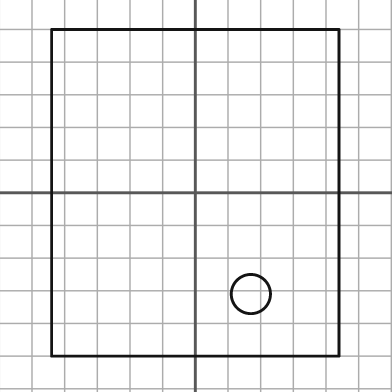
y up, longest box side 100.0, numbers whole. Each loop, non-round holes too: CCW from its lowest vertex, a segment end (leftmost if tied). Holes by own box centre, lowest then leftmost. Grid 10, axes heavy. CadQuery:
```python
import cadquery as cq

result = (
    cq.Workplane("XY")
    .moveTo(-44.0, -50.0)
    .lineTo(44.0, -50.0)
    .lineTo(44.0, 50.0)
    .lineTo(-44.0, 50.0)
    .close()
    .moveTo(17.0, -31.0)
    .circle(6.0)
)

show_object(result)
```